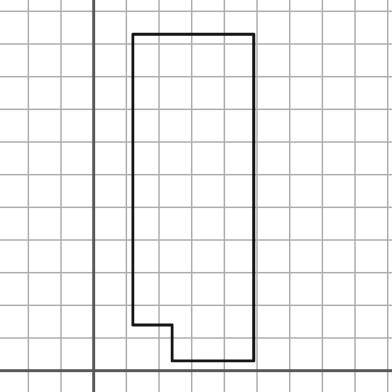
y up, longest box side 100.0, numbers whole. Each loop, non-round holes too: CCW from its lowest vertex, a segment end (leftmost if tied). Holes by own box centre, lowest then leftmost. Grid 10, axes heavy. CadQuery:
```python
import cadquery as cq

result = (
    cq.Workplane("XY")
    .moveTo(24.0, 3.0)
    .lineTo(49.0, 3.0)
    .lineTo(49.0, 103.0)
    .lineTo(12.0, 103.0)
    .lineTo(12.0, 14.0)
    .lineTo(24.0, 14.0)
    .close()
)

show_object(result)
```